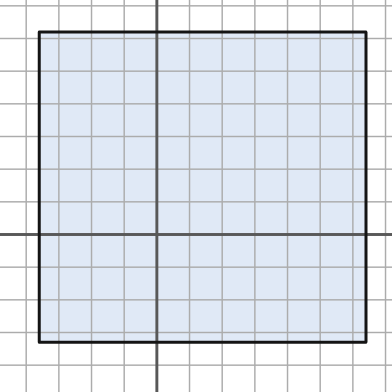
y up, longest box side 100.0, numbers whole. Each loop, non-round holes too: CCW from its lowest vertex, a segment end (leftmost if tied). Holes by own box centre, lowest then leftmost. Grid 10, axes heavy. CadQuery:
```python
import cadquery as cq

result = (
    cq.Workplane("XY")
    .moveTo(-36.0, -33.0)
    .lineTo(64.0, -33.0)
    .lineTo(64.0, 62.0)
    .lineTo(-36.0, 62.0)
    .close()
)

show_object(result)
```